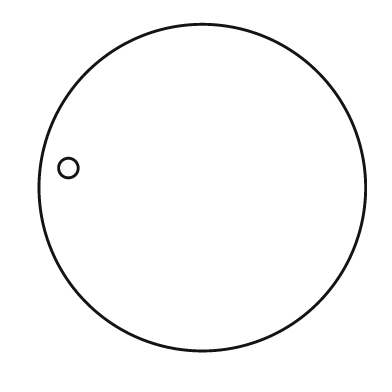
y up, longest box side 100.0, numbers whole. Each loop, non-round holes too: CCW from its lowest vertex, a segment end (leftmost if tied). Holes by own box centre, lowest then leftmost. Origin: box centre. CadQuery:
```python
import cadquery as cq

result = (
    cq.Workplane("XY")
    .moveTo(0.0, 0.0)
    .circle(50.0)
    .moveTo(-41.0, 6.0)
    .circle(3.0)
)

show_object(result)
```